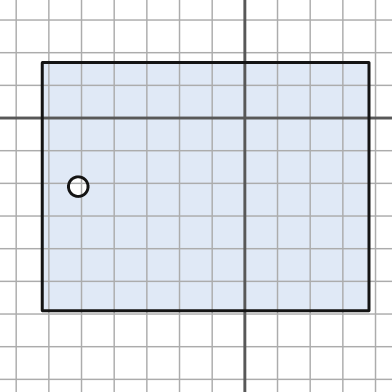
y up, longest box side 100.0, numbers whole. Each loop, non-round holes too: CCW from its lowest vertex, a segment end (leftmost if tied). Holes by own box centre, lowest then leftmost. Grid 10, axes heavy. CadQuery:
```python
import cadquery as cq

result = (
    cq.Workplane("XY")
    .moveTo(-62.0, -59.0)
    .lineTo(38.0, -59.0)
    .lineTo(38.0, 17.0)
    .lineTo(-62.0, 17.0)
    .close()
    .moveTo(-51.0, -21.0)
    .circle(3.0)
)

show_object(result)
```